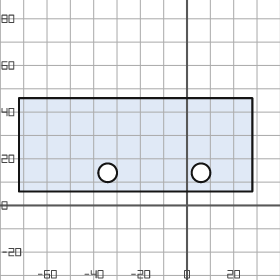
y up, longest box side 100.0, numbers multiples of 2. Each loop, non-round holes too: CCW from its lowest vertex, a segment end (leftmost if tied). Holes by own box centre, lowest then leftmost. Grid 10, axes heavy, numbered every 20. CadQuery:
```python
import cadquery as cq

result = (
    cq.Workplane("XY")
    .moveTo(-72.0, 6.0)
    .lineTo(28.0, 6.0)
    .lineTo(28.0, 46.0)
    .lineTo(-72.0, 46.0)
    .close()
    .moveTo(-34.0, 14.0)
    .circle(4.0)
    .moveTo(6.0, 14.0)
    .circle(4.0)
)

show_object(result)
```